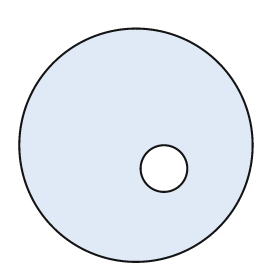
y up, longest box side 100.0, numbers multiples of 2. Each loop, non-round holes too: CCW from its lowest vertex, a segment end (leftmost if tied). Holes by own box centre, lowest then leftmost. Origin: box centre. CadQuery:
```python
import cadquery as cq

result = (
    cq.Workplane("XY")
    .moveTo(0.0, 0.0)
    .circle(50.0)
    .moveTo(12.0, -10.0)
    .circle(10.0)
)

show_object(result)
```